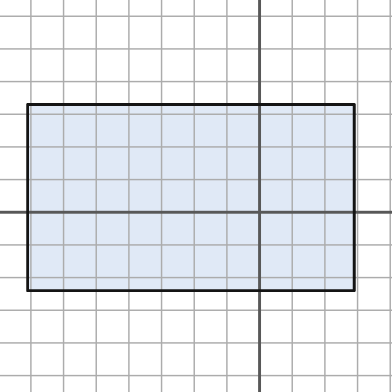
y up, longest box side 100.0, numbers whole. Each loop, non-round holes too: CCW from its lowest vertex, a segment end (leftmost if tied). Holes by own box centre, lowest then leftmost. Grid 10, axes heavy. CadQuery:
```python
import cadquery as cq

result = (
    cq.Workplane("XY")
    .moveTo(-71.0, -24.0)
    .lineTo(29.0, -24.0)
    .lineTo(29.0, 33.0)
    .lineTo(-71.0, 33.0)
    .close()
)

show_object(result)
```